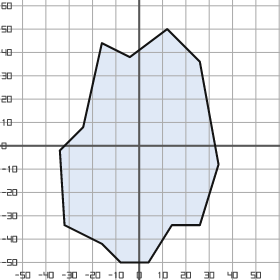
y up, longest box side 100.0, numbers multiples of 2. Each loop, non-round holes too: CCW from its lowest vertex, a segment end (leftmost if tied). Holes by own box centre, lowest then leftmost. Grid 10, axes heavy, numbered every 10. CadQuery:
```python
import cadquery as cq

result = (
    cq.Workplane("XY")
    .moveTo(-8.0, -50.0)
    .lineTo(4.0, -50.0)
    .lineTo(14.0, -34.0)
    .lineTo(26.0, -34.0)
    .lineTo(34.0, -8.0)
    .lineTo(26.0, 36.0)
    .lineTo(12.0, 50.0)
    .lineTo(-4.0, 38.0)
    .lineTo(-16.0, 44.0)
    .lineTo(-24.0, 8.0)
    .lineTo(-34.0, -2.0)
    .lineTo(-32.0, -34.0)
    .lineTo(-16.0, -42.0)
    .close()
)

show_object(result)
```